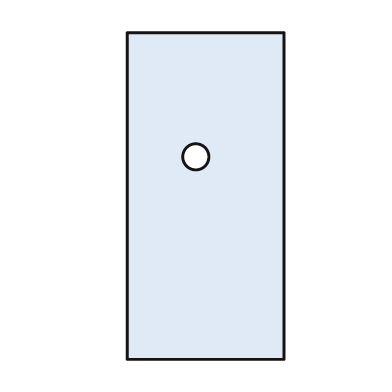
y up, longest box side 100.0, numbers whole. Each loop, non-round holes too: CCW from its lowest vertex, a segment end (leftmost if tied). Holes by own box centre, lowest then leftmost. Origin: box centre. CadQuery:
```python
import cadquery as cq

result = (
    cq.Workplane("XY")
    .moveTo(-24.0, -50.0)
    .lineTo(24.0, -50.0)
    .lineTo(24.0, 50.0)
    .lineTo(-24.0, 50.0)
    .close()
    .moveTo(-3.0, 12.0)
    .circle(4.0)
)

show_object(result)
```